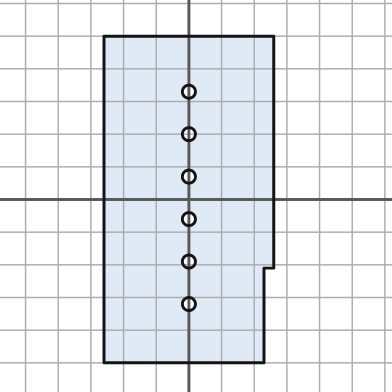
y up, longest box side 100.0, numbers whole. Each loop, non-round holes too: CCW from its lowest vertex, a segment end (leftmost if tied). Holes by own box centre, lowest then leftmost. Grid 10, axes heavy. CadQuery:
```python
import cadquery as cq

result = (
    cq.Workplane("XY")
    .moveTo(-26.0, -50.0)
    .lineTo(23.0, -50.0)
    .lineTo(23.0, -21.0)
    .lineTo(26.0, -21.0)
    .lineTo(26.0, 50.0)
    .lineTo(-26.0, 50.0)
    .close()
    .moveTo(0.0, -32.0)
    .circle(2.0)
    .moveTo(0.0, -19.0)
    .circle(2.0)
    .moveTo(0.0, -6.0)
    .circle(2.0)
    .moveTo(0.0, 7.0)
    .circle(2.0)
    .moveTo(0.0, 20.0)
    .circle(2.0)
    .moveTo(0.0, 33.0)
    .circle(2.0)
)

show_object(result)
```